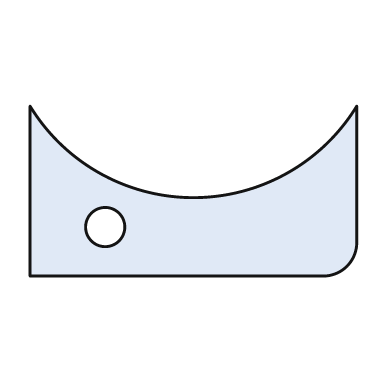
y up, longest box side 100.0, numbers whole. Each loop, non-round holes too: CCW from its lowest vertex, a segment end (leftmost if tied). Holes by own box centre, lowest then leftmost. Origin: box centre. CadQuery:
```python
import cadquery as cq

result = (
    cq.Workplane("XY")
    .moveTo(-50.0, -26.0)
    .lineTo(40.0, -26.0)
    .threePointArc((47.0, -23.0), (50.0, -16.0))
    .lineTo(50.0, 26.0)
    .threePointArc((0.0, -2.0), (-50.0, 26.0))
    .close()
    .moveTo(-27.0, -11.0)
    .circle(6.0)
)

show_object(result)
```